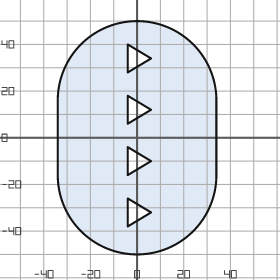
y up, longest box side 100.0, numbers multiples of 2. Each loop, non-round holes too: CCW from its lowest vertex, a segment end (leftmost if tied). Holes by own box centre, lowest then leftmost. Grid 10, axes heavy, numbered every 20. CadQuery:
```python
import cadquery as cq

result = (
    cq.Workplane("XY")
    .moveTo(-34.0, -16.0)
    .threePointArc((0.0, -50.0), (34.0, -16.0))
    .lineTo(34.0, 16.0)
    .threePointArc((0.0, 50.0), (-34.0, 16.0))
    .close()
    .moveTo(-4.0, -38.0)
    .lineTo(6.0, -32.0)
    .lineTo(-4.0, -26.0)
    .close()
    .moveTo(-4.0, -16.0)
    .lineTo(6.0, -10.0)
    .lineTo(-4.0, -4.0)
    .close()
    .moveTo(-4.0, 6.0)
    .lineTo(6.0, 12.0)
    .lineTo(-4.0, 18.0)
    .close()
    .moveTo(-4.0, 28.0)
    .lineTo(6.0, 34.0)
    .lineTo(-4.0, 40.0)
    .close()
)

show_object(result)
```